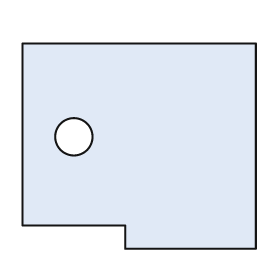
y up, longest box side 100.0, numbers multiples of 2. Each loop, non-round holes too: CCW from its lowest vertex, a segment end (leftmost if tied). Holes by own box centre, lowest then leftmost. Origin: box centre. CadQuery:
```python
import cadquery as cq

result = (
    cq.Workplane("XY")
    .moveTo(-6.0, -44.0)
    .lineTo(50.0, -44.0)
    .lineTo(50.0, 44.0)
    .lineTo(-50.0, 44.0)
    .lineTo(-50.0, -34.0)
    .lineTo(-6.0, -34.0)
    .close()
    .moveTo(-28.0, 4.0)
    .circle(8.0)
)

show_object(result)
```